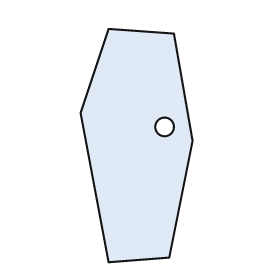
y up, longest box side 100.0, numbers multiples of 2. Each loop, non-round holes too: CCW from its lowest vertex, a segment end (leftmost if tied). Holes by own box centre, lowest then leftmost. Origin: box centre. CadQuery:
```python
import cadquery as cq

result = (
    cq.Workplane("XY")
    .moveTo(-12.0, -50.0)
    .lineTo(14.0, -48.0)
    .lineTo(24.0, 2.0)
    .lineTo(16.0, 48.0)
    .lineTo(-12.0, 50.0)
    .lineTo(-24.0, 14.0)
    .close()
    .moveTo(12.0, 8.0)
    .circle(4.0)
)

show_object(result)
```